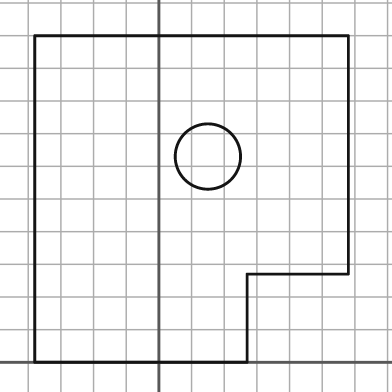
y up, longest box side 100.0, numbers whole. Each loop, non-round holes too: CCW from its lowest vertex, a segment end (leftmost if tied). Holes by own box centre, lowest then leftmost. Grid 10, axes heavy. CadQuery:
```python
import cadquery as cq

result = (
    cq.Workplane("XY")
    .moveTo(-38.0, 0.0)
    .lineTo(27.0, 0.0)
    .lineTo(27.0, 27.0)
    .lineTo(58.0, 27.0)
    .lineTo(58.0, 100.0)
    .lineTo(-38.0, 100.0)
    .close()
    .moveTo(15.0, 63.0)
    .circle(10.0)
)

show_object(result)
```